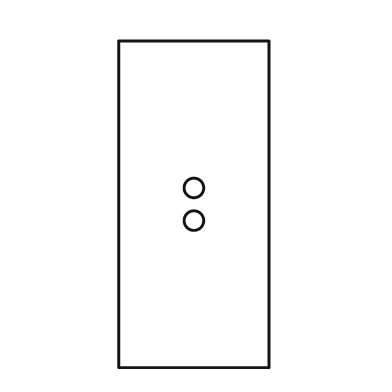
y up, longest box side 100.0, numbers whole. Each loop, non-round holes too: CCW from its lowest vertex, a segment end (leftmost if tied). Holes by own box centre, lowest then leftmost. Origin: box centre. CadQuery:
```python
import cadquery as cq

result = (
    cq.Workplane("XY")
    .moveTo(-23.0, -50.0)
    .lineTo(23.0, -50.0)
    .lineTo(23.0, 50.0)
    .lineTo(-23.0, 50.0)
    .close()
    .moveTo(0.0, -5.0)
    .circle(3.0)
    .moveTo(0.0, 5.0)
    .circle(3.0)
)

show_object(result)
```